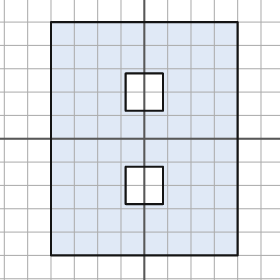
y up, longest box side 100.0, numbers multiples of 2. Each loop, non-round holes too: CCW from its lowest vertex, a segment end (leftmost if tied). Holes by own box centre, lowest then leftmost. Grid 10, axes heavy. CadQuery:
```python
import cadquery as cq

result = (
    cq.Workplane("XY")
    .moveTo(-40.0, -50.0)
    .lineTo(40.0, -50.0)
    .lineTo(40.0, 50.0)
    .lineTo(-40.0, 50.0)
    .close()
    .moveTo(-8.0, -28.0)
    .lineTo(8.0, -28.0)
    .lineTo(8.0, -12.0)
    .lineTo(-8.0, -12.0)
    .close()
    .moveTo(-8.0, 12.0)
    .lineTo(8.0, 12.0)
    .lineTo(8.0, 28.0)
    .lineTo(-8.0, 28.0)
    .close()
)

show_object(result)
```